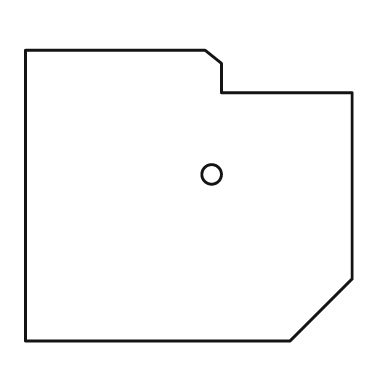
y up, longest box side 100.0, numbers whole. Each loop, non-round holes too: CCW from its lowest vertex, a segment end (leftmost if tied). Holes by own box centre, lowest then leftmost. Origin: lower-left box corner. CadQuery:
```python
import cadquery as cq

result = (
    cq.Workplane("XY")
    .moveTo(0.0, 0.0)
    .lineTo(81.0, 0.0)
    .lineTo(100.0, 19.0)
    .lineTo(100.0, 76.0)
    .lineTo(60.0, 76.0)
    .lineTo(60.0, 85.0)
    .lineTo(55.0, 89.0)
    .lineTo(0.0, 89.0)
    .close()
    .moveTo(57.0, 51.0)
    .circle(3.0)
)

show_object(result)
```